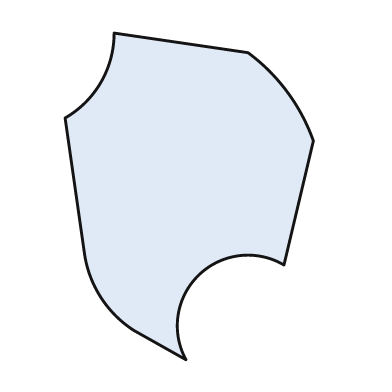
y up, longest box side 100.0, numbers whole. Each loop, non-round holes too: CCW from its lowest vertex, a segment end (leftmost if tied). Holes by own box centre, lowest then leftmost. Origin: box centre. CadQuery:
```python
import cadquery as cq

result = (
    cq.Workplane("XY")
    .moveTo(-1.0, -50.0)
    .threePointArc((3.0, -24.0), (29.0, -21.0))
    .lineTo(38.0, 17.0)
    .threePointArc((30.0, 32.0), (18.0, 44.0))
    .lineTo(-23.0, 50.0)
    .threePointArc((-27.0, 35.0), (-38.0, 24.0))
    .lineTo(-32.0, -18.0)
    .threePointArc((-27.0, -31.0), (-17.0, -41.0))
    .close()
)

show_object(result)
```